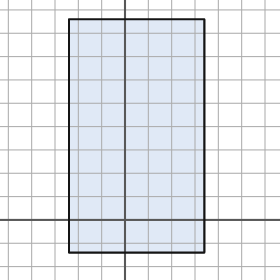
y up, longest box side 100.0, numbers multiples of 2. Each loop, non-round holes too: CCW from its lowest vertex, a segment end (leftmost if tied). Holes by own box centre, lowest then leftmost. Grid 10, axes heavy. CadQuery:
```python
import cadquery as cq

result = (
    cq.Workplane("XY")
    .moveTo(-24.0, -14.0)
    .lineTo(34.0, -14.0)
    .lineTo(34.0, 86.0)
    .lineTo(-24.0, 86.0)
    .close()
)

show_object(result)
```